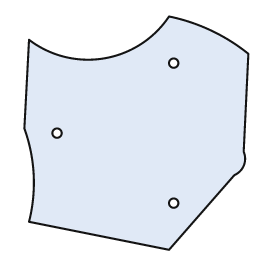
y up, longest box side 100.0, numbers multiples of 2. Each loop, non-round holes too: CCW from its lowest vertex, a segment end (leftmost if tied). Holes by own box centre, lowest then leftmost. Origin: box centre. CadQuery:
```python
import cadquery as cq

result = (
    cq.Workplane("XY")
    .moveTo(14.0, -50.0)
    .lineTo(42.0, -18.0)
    .threePointArc((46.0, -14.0), (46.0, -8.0))
    .lineTo(48.0, 34.0)
    .threePointArc((32.0, 44.0), (14.0, 50.0))
    .threePointArc((-14.0, 32.0), (-46.0, 40.0))
    .lineTo(-48.0, 2.0)
    .threePointArc((-44.0, -18.0), (-46.0, -38.0))
    .close()
    .moveTo(16.0, -30.0)
    .circle(2.0)
    .moveTo(-34.0, 0.0)
    .circle(2.0)
    .moveTo(16.0, 30.0)
    .circle(2.0)
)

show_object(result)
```